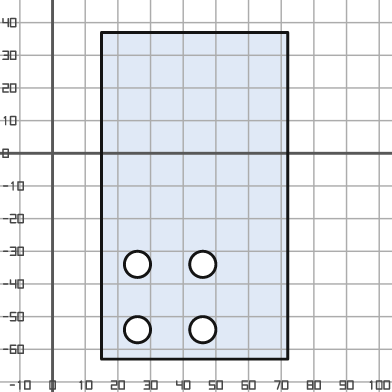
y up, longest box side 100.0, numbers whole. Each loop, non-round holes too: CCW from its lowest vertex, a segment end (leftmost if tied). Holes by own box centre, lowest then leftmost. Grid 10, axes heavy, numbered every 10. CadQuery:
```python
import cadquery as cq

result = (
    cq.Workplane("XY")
    .moveTo(15.0, -63.0)
    .lineTo(72.0, -63.0)
    .lineTo(72.0, 37.0)
    .lineTo(15.0, 37.0)
    .close()
    .moveTo(26.0, -54.0)
    .circle(4.0)
    .moveTo(46.0, -54.0)
    .circle(4.0)
    .moveTo(26.0, -34.0)
    .circle(4.0)
    .moveTo(46.0, -34.0)
    .circle(4.0)
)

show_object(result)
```